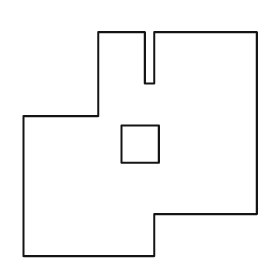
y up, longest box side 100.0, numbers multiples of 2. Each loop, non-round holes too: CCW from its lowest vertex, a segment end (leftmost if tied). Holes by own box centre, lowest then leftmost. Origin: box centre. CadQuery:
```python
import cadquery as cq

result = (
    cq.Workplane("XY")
    .moveTo(-50.0, -48.0)
    .lineTo(6.0, -48.0)
    .lineTo(6.0, -30.0)
    .lineTo(50.0, -30.0)
    .lineTo(50.0, 48.0)
    .lineTo(6.0, 48.0)
    .lineTo(6.0, 26.0)
    .lineTo(2.0, 26.0)
    .lineTo(2.0, 48.0)
    .lineTo(-18.0, 48.0)
    .lineTo(-18.0, 12.0)
    .lineTo(-50.0, 12.0)
    .close()
    .moveTo(-8.0, -8.0)
    .lineTo(8.0, -8.0)
    .lineTo(8.0, 8.0)
    .lineTo(-8.0, 8.0)
    .close()
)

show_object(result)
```